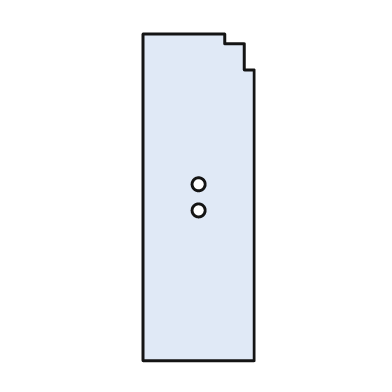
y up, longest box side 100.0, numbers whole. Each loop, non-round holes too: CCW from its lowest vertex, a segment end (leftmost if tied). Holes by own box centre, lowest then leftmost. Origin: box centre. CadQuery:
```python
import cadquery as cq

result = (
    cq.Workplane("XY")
    .moveTo(-17.0, -50.0)
    .lineTo(17.0, -50.0)
    .lineTo(17.0, 39.0)
    .lineTo(14.0, 39.0)
    .lineTo(14.0, 47.0)
    .lineTo(8.0, 47.0)
    .lineTo(8.0, 50.0)
    .lineTo(-17.0, 50.0)
    .close()
    .moveTo(0.0, -4.0)
    .circle(2.0)
    .moveTo(0.0, 4.0)
    .circle(2.0)
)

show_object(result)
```